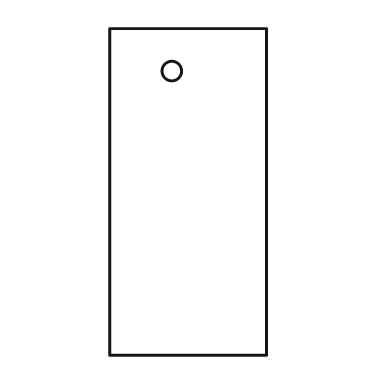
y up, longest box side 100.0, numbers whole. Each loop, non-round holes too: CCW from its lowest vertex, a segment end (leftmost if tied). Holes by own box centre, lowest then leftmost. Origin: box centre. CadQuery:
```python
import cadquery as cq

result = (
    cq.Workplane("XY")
    .moveTo(-24.0, -50.0)
    .lineTo(24.0, -50.0)
    .lineTo(24.0, 50.0)
    .lineTo(-24.0, 50.0)
    .close()
    .moveTo(-5.0, 37.0)
    .circle(3.0)
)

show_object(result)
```